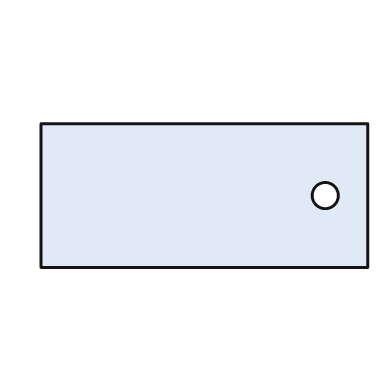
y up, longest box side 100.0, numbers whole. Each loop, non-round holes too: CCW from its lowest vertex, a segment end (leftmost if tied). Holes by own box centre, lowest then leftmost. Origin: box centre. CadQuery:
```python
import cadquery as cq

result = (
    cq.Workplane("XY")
    .moveTo(-50.0, -22.0)
    .lineTo(50.0, -22.0)
    .lineTo(50.0, 22.0)
    .lineTo(-50.0, 22.0)
    .close()
    .moveTo(37.0, 0.0)
    .circle(4.0)
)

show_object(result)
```